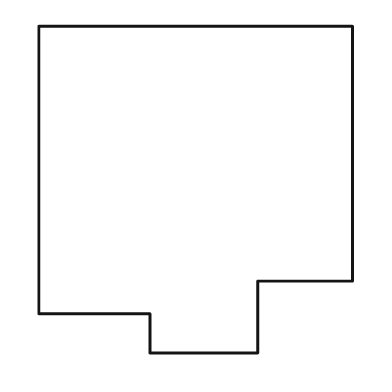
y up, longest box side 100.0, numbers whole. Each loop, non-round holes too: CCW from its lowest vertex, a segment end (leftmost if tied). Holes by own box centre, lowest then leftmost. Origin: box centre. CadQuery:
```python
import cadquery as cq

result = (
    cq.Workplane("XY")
    .moveTo(-14.0, -50.0)
    .lineTo(19.0, -50.0)
    .lineTo(19.0, -28.0)
    .lineTo(48.0, -28.0)
    .lineTo(48.0, 50.0)
    .lineTo(-48.0, 50.0)
    .lineTo(-48.0, -38.0)
    .lineTo(-14.0, -38.0)
    .close()
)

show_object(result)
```